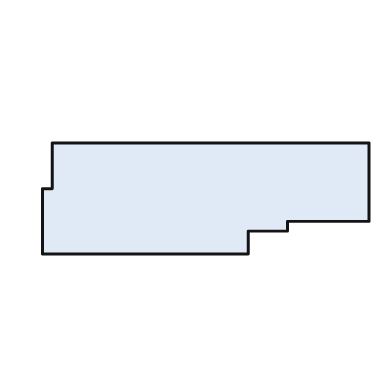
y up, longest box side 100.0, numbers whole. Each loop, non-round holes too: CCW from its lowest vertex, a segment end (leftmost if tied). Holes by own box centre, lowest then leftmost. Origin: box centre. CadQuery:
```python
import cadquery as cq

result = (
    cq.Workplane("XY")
    .moveTo(-50.0, -17.0)
    .lineTo(13.0, -17.0)
    .lineTo(13.0, -10.0)
    .lineTo(25.0, -10.0)
    .lineTo(25.0, -7.0)
    .lineTo(50.0, -7.0)
    .lineTo(50.0, 17.0)
    .lineTo(-47.0, 17.0)
    .lineTo(-47.0, 3.0)
    .lineTo(-50.0, 3.0)
    .close()
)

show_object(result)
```